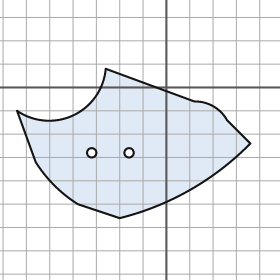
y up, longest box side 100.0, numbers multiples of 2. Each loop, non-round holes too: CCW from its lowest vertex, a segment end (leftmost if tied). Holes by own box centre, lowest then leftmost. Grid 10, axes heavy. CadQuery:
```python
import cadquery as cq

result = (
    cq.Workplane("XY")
    .moveTo(-20.0, -56.0)
    .threePointArc((10.0, -44.0), (36.0, -24.0))
    .lineTo(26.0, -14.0)
    .threePointArc((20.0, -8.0), (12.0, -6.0))
    .lineTo(-26.0, 8.0)
    .threePointArc((-40.0, -12.0), (-64.0, -10.0))
    .lineTo(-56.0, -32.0)
    .threePointArc((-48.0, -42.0), (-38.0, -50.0))
    .close()
    .moveTo(-32.0, -28.0)
    .circle(2.0)
    .moveTo(-16.0, -28.0)
    .circle(2.0)
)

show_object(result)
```